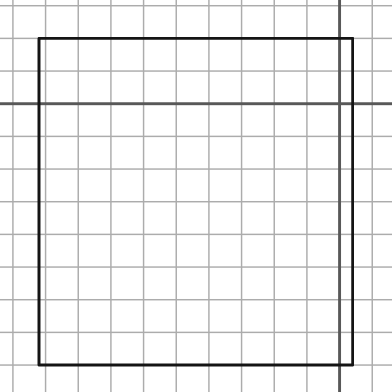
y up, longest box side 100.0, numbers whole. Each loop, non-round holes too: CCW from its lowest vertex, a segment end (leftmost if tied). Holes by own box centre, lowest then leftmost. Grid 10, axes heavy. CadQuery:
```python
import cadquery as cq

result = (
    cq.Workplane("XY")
    .moveTo(-92.0, -80.0)
    .lineTo(4.0, -80.0)
    .lineTo(4.0, 20.0)
    .lineTo(-92.0, 20.0)
    .close()
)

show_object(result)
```